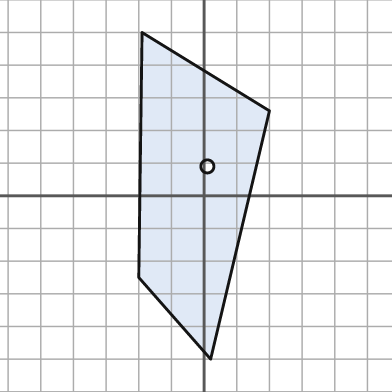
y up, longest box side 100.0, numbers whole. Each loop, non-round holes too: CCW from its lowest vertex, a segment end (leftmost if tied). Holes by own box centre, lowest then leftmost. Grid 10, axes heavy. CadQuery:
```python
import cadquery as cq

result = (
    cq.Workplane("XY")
    .moveTo(2.0, -50.0)
    .lineTo(20.0, 26.0)
    .lineTo(-19.0, 50.0)
    .lineTo(-20.0, -25.0)
    .close()
    .moveTo(1.0, 9.0)
    .circle(2.0)
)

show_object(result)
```